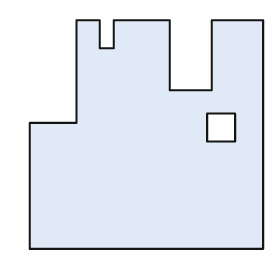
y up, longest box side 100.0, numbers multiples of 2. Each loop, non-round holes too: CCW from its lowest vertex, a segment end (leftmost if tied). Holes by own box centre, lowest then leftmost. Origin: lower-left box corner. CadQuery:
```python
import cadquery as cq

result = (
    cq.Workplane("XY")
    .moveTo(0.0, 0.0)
    .lineTo(100.0, 0.0)
    .lineTo(100.0, 98.0)
    .lineTo(78.0, 98.0)
    .lineTo(78.0, 68.0)
    .lineTo(60.0, 68.0)
    .lineTo(60.0, 98.0)
    .lineTo(36.0, 98.0)
    .lineTo(36.0, 86.0)
    .lineTo(30.0, 86.0)
    .lineTo(30.0, 98.0)
    .lineTo(20.0, 98.0)
    .lineTo(20.0, 54.0)
    .lineTo(0.0, 54.0)
    .close()
    .moveTo(76.0, 46.0)
    .lineTo(88.0, 46.0)
    .lineTo(88.0, 58.0)
    .lineTo(76.0, 58.0)
    .close()
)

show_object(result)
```